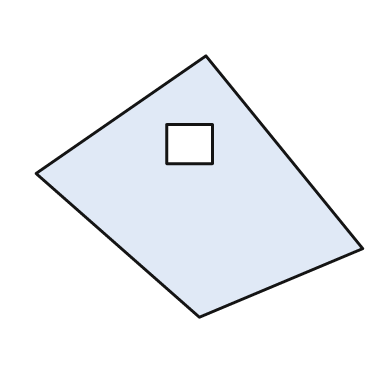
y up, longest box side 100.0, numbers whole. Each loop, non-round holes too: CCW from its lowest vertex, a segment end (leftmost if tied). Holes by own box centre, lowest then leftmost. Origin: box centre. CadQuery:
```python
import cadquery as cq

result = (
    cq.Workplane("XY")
    .moveTo(0.0, -40.0)
    .lineTo(50.0, -19.0)
    .lineTo(2.0, 40.0)
    .lineTo(-50.0, 4.0)
    .close()
    .moveTo(-10.0, 7.0)
    .lineTo(4.0, 7.0)
    .lineTo(4.0, 19.0)
    .lineTo(-10.0, 19.0)
    .close()
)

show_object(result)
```